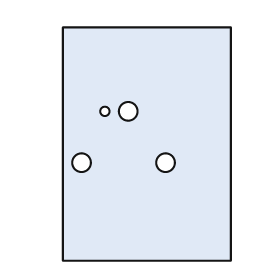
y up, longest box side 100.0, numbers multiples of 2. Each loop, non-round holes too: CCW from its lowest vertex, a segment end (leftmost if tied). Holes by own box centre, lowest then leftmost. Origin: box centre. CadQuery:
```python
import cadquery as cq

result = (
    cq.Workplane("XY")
    .moveTo(-36.0, -50.0)
    .lineTo(36.0, -50.0)
    .lineTo(36.0, 50.0)
    .lineTo(-36.0, 50.0)
    .close()
    .moveTo(-28.0, -8.0)
    .circle(4.0)
    .moveTo(8.0, -8.0)
    .circle(4.0)
    .moveTo(-18.0, 14.0)
    .circle(2.0)
    .moveTo(-8.0, 14.0)
    .circle(4.0)
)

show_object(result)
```